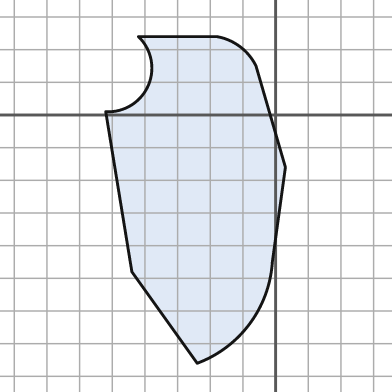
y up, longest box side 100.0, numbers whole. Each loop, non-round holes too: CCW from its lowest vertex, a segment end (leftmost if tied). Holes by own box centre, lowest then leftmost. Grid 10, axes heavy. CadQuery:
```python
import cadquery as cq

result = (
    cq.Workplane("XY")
    .moveTo(-24.0, -76.0)
    .threePointArc((-8.0, -64.0), (-1.0, -45.0))
    .lineTo(3.0, -16.0)
    .lineTo(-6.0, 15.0)
    .threePointArc((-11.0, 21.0), (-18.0, 24.0))
    .lineTo(-42.0, 24.0)
    .threePointArc((-39.0, 9.0), (-52.0, 1.0))
    .lineTo(-44.0, -48.0)
    .close()
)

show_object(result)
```